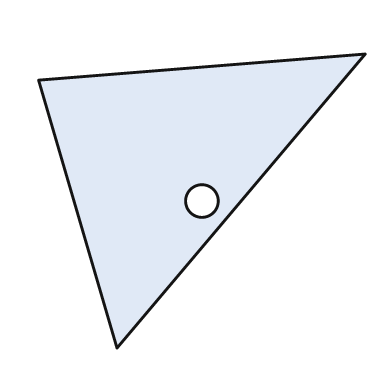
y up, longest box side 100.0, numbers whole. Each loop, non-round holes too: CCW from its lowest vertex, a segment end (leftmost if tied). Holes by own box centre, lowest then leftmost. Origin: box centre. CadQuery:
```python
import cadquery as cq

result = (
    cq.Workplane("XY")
    .moveTo(-26.0, -45.0)
    .lineTo(50.0, 45.0)
    .lineTo(-50.0, 37.0)
    .close()
    .moveTo(0.0, 0.0)
    .circle(5.0)
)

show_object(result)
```